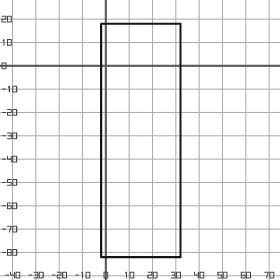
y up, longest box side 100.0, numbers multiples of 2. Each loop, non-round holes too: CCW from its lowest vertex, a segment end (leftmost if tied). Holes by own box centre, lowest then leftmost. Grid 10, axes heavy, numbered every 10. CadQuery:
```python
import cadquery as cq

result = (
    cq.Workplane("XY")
    .moveTo(-2.0, -82.0)
    .lineTo(32.0, -82.0)
    .lineTo(32.0, 18.0)
    .lineTo(-2.0, 18.0)
    .close()
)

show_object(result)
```